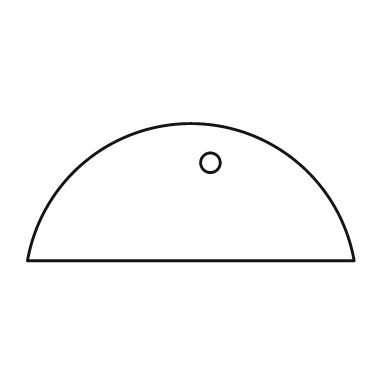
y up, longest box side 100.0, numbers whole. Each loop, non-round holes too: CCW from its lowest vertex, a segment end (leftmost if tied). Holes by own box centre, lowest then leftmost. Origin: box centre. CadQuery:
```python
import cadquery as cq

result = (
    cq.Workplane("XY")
    .moveTo(-50.0, -21.0)
    .lineTo(50.0, -21.0)
    .threePointArc((0.0, 21.0), (-50.0, -21.0))
    .close()
    .moveTo(6.0, 9.0)
    .circle(3.0)
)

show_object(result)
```